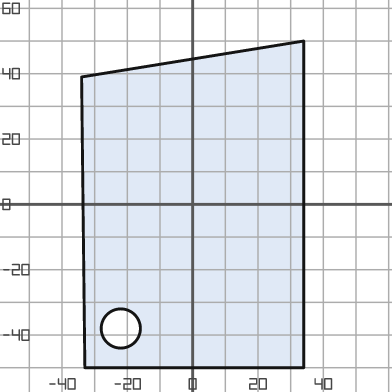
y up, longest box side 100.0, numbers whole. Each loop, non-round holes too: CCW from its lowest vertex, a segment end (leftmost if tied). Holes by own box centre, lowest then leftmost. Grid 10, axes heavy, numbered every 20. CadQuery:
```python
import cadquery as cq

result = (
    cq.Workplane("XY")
    .moveTo(-33.0, -50.0)
    .lineTo(34.0, -50.0)
    .lineTo(34.0, 50.0)
    .lineTo(-34.0, 39.0)
    .close()
    .moveTo(-22.0, -38.0)
    .circle(6.0)
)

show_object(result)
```